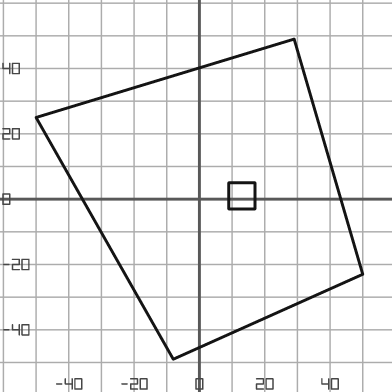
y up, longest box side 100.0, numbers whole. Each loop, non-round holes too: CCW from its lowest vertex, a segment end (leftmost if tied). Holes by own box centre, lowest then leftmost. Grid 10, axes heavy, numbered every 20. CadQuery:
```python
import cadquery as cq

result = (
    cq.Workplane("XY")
    .moveTo(-8.0, -49.0)
    .lineTo(50.0, -23.0)
    .lineTo(29.0, 49.0)
    .lineTo(-50.0, 25.0)
    .close()
    .moveTo(9.0, -3.0)
    .lineTo(17.0, -3.0)
    .lineTo(17.0, 5.0)
    .lineTo(9.0, 5.0)
    .close()
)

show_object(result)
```